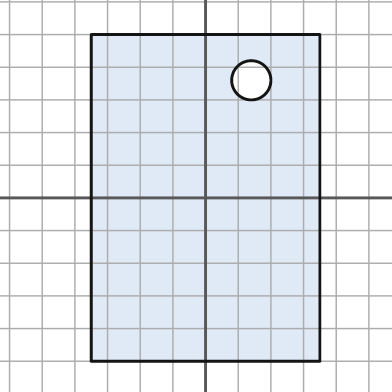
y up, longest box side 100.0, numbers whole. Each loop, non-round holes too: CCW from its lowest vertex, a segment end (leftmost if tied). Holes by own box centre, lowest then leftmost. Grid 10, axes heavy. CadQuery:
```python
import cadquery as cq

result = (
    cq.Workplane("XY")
    .moveTo(-35.0, -50.0)
    .lineTo(35.0, -50.0)
    .lineTo(35.0, 50.0)
    .lineTo(-35.0, 50.0)
    .close()
    .moveTo(14.0, 36.0)
    .circle(6.0)
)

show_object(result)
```